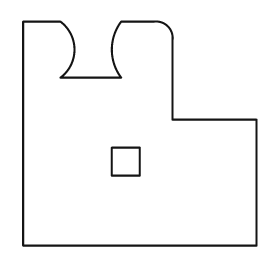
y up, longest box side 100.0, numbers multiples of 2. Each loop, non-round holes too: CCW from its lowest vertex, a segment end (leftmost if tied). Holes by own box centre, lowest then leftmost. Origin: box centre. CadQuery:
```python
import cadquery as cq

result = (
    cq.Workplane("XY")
    .moveTo(-50.0, -48.0)
    .lineTo(50.0, -48.0)
    .lineTo(50.0, 6.0)
    .lineTo(14.0, 6.0)
    .lineTo(14.0, 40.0)
    .threePointArc((12.0, 46.0), (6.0, 48.0))
    .lineTo(-8.0, 48.0)
    .threePointArc((-12.0, 36.0), (-8.0, 24.0))
    .lineTo(-34.0, 24.0)
    .threePointArc((-28.0, 36.0), (-34.0, 48.0))
    .lineTo(-50.0, 48.0)
    .close()
    .moveTo(-12.0, -18.0)
    .lineTo(0.0, -18.0)
    .lineTo(0.0, -6.0)
    .lineTo(-12.0, -6.0)
    .close()
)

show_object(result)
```